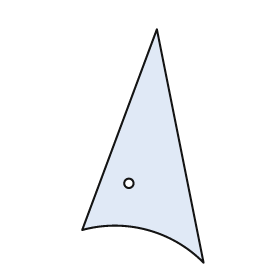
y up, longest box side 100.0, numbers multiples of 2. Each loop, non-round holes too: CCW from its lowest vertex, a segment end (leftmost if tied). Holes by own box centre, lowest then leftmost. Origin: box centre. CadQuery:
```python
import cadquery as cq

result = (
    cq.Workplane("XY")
    .moveTo(26.0, -50.0)
    .lineTo(6.0, 50.0)
    .lineTo(-26.0, -36.0)
    .threePointArc((2.0, -36.0), (26.0, -50.0))
    .close()
    .moveTo(-6.0, -16.0)
    .circle(2.0)
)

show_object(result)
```